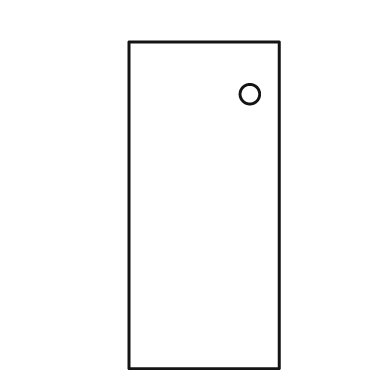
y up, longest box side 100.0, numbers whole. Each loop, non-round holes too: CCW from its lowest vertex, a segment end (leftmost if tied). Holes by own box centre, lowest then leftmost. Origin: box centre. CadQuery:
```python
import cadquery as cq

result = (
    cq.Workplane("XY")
    .moveTo(-23.0, -50.0)
    .lineTo(23.0, -50.0)
    .lineTo(23.0, 50.0)
    .lineTo(-23.0, 50.0)
    .close()
    .moveTo(14.0, 34.0)
    .circle(3.0)
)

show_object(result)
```